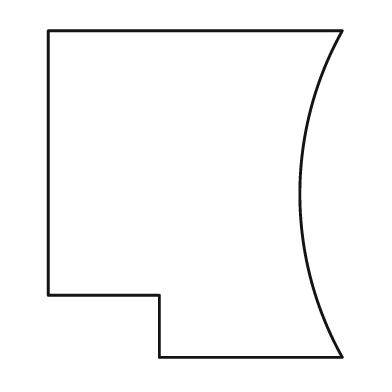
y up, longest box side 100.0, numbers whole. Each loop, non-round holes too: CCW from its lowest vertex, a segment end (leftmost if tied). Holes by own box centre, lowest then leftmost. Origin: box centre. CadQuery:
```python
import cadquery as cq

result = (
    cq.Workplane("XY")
    .moveTo(-11.0, -50.0)
    .lineTo(45.0, -50.0)
    .threePointArc((32.0, 0.0), (45.0, 50.0))
    .lineTo(-45.0, 50.0)
    .lineTo(-45.0, -31.0)
    .lineTo(-11.0, -31.0)
    .close()
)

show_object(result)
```